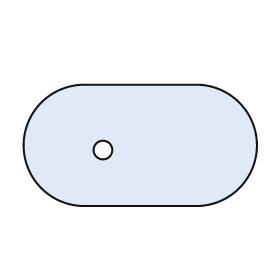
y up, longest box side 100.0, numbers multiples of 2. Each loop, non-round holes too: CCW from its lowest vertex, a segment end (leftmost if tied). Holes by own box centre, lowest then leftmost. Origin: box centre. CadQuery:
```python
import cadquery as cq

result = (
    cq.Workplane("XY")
    .moveTo(-24.0, -26.0)
    .lineTo(24.0, -26.0)
    .threePointArc((50.0, 0.0), (24.0, 26.0))
    .lineTo(-24.0, 26.0)
    .threePointArc((-50.0, 0.0), (-24.0, -26.0))
    .close()
    .moveTo(-16.0, -2.0)
    .circle(4.0)
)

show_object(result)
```